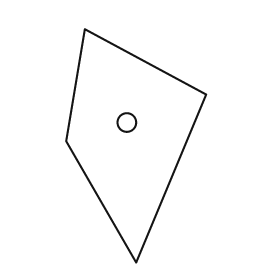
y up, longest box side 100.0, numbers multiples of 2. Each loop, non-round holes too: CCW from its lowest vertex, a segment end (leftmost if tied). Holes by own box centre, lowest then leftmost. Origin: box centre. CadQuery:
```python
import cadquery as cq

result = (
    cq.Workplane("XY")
    .moveTo(0.0, -50.0)
    .lineTo(30.0, 22.0)
    .lineTo(-22.0, 50.0)
    .lineTo(-30.0, 2.0)
    .close()
    .moveTo(-4.0, 10.0)
    .circle(4.0)
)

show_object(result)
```